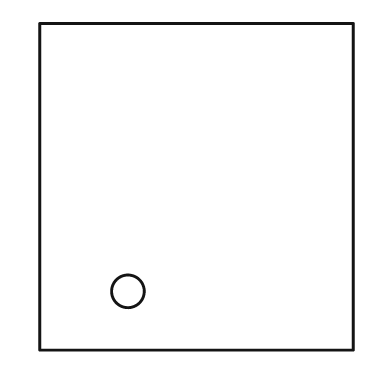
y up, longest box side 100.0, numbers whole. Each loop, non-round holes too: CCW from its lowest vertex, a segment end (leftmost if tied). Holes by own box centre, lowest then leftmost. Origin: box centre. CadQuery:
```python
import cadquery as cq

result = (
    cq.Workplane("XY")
    .moveTo(-48.0, -50.0)
    .lineTo(48.0, -50.0)
    .lineTo(48.0, 50.0)
    .lineTo(-48.0, 50.0)
    .close()
    .moveTo(-21.0, -32.0)
    .circle(5.0)
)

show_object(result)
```